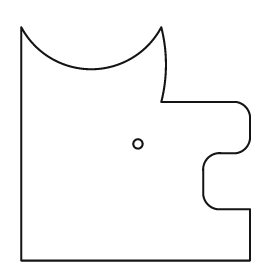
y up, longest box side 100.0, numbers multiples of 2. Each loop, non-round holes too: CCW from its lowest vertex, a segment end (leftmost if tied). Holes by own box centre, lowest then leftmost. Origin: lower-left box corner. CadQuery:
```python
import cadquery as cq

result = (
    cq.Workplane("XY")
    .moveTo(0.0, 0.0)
    .lineTo(98.0, 0.0)
    .lineTo(98.0, 22.0)
    .lineTo(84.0, 22.0)
    .threePointArc((80.0, 24.0), (78.0, 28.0))
    .lineTo(78.0, 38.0)
    .threePointArc((80.0, 44.0), (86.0, 46.0))
    .lineTo(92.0, 46.0)
    .threePointArc((96.0, 48.0), (98.0, 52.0))
    .lineTo(98.0, 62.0)
    .threePointArc((96.0, 66.0), (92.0, 68.0))
    .lineTo(60.0, 68.0)
    .threePointArc((62.0, 84.0), (60.0, 100.0))
    .threePointArc((30.0, 82.0), (0.0, 100.0))
    .close()
    .moveTo(50.0, 50.0)
    .circle(2.0)
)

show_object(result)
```